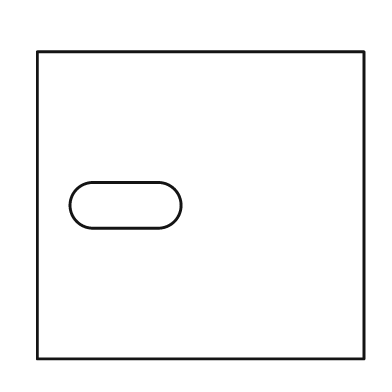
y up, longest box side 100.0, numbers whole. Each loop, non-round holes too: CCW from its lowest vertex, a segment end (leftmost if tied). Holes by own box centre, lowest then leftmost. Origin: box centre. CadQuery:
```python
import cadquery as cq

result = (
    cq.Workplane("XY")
    .moveTo(-50.0, -47.0)
    .lineTo(50.0, -47.0)
    .lineTo(50.0, 47.0)
    .lineTo(-50.0, 47.0)
    .close()
    .moveTo(-33.0, -7.0)
    .lineTo(-13.0, -7.0)
    .threePointArc((-6.0, 0.0), (-13.0, 7.0))
    .lineTo(-33.0, 7.0)
    .threePointArc((-40.0, 0.0), (-33.0, -7.0))
    .close()
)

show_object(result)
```